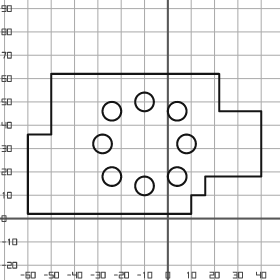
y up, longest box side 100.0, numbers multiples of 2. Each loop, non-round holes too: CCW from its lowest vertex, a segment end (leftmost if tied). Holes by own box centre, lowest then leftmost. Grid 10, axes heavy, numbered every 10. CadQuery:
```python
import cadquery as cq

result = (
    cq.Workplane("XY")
    .moveTo(-60.0, 2.0)
    .lineTo(10.0, 2.0)
    .lineTo(10.0, 10.0)
    .lineTo(16.0, 10.0)
    .lineTo(16.0, 18.0)
    .lineTo(40.0, 18.0)
    .lineTo(40.0, 46.0)
    .lineTo(22.0, 46.0)
    .lineTo(22.0, 62.0)
    .lineTo(-50.0, 62.0)
    .lineTo(-50.0, 36.0)
    .lineTo(-60.0, 36.0)
    .close()
    .moveTo(-10.0, 14.0)
    .circle(4.0)
    .moveTo(-24.0, 18.0)
    .circle(4.0)
    .moveTo(4.0, 18.0)
    .circle(4.0)
    .moveTo(-28.0, 32.0)
    .circle(4.0)
    .moveTo(8.0, 32.0)
    .circle(4.0)
    .moveTo(-24.0, 46.0)
    .circle(4.0)
    .moveTo(4.0, 46.0)
    .circle(4.0)
    .moveTo(-10.0, 50.0)
    .circle(4.0)
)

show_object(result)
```